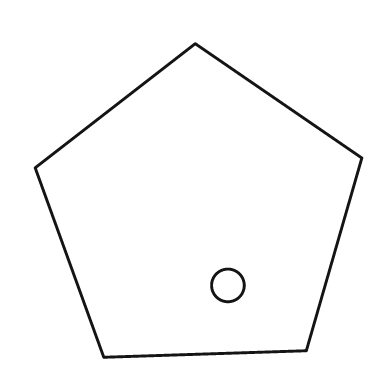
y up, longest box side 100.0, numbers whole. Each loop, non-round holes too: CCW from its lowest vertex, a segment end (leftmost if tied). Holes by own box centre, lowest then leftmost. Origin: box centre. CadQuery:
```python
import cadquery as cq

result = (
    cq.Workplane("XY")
    .moveTo(-29.0, -48.0)
    .lineTo(33.0, -46.0)
    .lineTo(50.0, 13.0)
    .lineTo(-1.0, 48.0)
    .lineTo(-50.0, 10.0)
    .close()
    .moveTo(9.0, -26.0)
    .circle(5.0)
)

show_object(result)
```